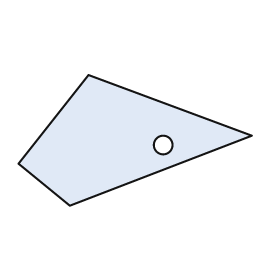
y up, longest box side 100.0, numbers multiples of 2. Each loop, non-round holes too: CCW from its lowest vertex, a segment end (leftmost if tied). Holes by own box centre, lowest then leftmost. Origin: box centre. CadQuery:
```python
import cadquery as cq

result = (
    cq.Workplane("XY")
    .moveTo(-28.0, -28.0)
    .lineTo(50.0, 2.0)
    .lineTo(-20.0, 28.0)
    .lineTo(-50.0, -10.0)
    .close()
    .moveTo(12.0, -2.0)
    .circle(4.0)
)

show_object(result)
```